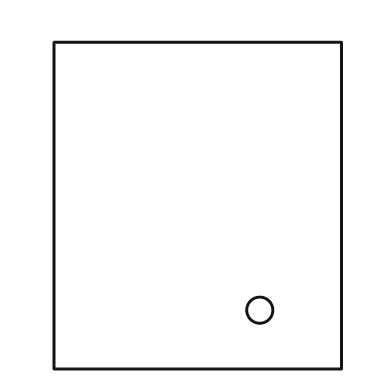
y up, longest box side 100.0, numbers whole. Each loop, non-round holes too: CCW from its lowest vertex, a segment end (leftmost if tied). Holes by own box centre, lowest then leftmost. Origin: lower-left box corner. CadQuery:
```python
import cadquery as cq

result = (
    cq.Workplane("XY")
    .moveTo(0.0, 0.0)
    .lineTo(88.0, 0.0)
    .lineTo(88.0, 100.0)
    .lineTo(0.0, 100.0)
    .close()
    .moveTo(63.0, 18.0)
    .circle(4.0)
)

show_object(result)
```